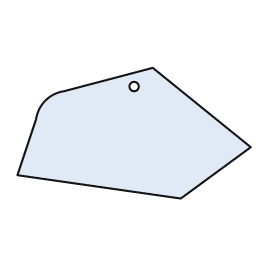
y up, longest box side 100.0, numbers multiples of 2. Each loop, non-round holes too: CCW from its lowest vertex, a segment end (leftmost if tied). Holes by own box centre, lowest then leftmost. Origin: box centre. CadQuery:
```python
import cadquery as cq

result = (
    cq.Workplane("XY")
    .moveTo(20.0, -28.0)
    .lineTo(50.0, -6.0)
    .lineTo(8.0, 28.0)
    .lineTo(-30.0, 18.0)
    .threePointArc((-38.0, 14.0), (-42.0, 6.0))
    .lineTo(-50.0, -18.0)
    .close()
    .moveTo(0.0, 20.0)
    .circle(2.0)
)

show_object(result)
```